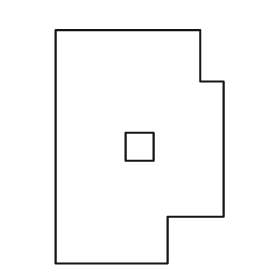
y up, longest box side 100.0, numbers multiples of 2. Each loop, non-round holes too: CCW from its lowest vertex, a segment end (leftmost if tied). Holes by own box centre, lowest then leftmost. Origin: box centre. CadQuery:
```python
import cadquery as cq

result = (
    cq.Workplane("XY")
    .moveTo(-36.0, -50.0)
    .lineTo(12.0, -50.0)
    .lineTo(12.0, -30.0)
    .lineTo(36.0, -30.0)
    .lineTo(36.0, 28.0)
    .lineTo(26.0, 28.0)
    .lineTo(26.0, 50.0)
    .lineTo(-36.0, 50.0)
    .close()
    .moveTo(-6.0, -6.0)
    .lineTo(6.0, -6.0)
    .lineTo(6.0, 6.0)
    .lineTo(-6.0, 6.0)
    .close()
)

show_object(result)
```